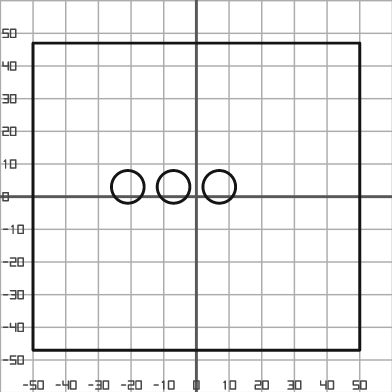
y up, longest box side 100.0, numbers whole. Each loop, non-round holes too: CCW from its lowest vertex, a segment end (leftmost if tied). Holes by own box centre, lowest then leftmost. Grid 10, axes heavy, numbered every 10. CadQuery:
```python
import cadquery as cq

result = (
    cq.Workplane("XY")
    .moveTo(-50.0, -47.0)
    .lineTo(50.0, -47.0)
    .lineTo(50.0, 47.0)
    .lineTo(-50.0, 47.0)
    .close()
    .moveTo(-21.0, 3.0)
    .circle(5.0)
    .moveTo(-7.0, 3.0)
    .circle(5.0)
    .moveTo(7.0, 3.0)
    .circle(5.0)
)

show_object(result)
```